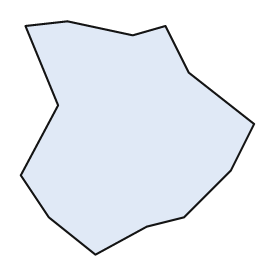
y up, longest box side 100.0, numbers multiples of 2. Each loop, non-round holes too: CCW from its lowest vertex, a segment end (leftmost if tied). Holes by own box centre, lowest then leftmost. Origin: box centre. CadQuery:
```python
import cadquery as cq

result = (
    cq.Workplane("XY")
    .moveTo(-18.0, -50.0)
    .lineTo(4.0, -38.0)
    .lineTo(20.0, -34.0)
    .lineTo(40.0, -14.0)
    .lineTo(50.0, 6.0)
    .lineTo(22.0, 28.0)
    .lineTo(12.0, 48.0)
    .lineTo(-2.0, 44.0)
    .lineTo(-30.0, 50.0)
    .lineTo(-48.0, 48.0)
    .lineTo(-34.0, 14.0)
    .lineTo(-50.0, -16.0)
    .lineTo(-38.0, -34.0)
    .close()
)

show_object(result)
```